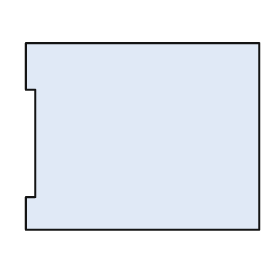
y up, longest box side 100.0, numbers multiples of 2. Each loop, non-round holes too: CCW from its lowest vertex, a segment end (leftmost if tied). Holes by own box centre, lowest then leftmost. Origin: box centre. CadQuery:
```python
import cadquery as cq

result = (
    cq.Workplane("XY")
    .moveTo(-50.0, -40.0)
    .lineTo(50.0, -40.0)
    .lineTo(50.0, 40.0)
    .lineTo(-50.0, 40.0)
    .lineTo(-50.0, 20.0)
    .lineTo(-46.0, 20.0)
    .lineTo(-46.0, -26.0)
    .lineTo(-50.0, -26.0)
    .close()
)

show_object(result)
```